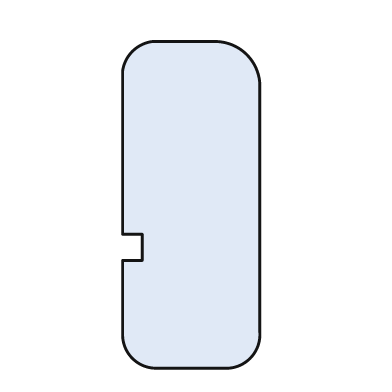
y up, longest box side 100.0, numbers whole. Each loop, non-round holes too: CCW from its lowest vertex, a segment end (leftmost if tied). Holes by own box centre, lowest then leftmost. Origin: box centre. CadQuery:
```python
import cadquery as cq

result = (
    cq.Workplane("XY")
    .moveTo(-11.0, -50.0)
    .lineTo(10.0, -50.0)
    .threePointArc((18.0, -47.0), (21.0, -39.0))
    .lineTo(21.0, 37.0)
    .threePointArc((17.0, 46.0), (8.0, 50.0))
    .lineTo(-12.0, 50.0)
    .threePointArc((-18.0, 47.0), (-21.0, 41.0))
    .lineTo(-21.0, -9.0)
    .lineTo(-15.0, -9.0)
    .lineTo(-15.0, -17.0)
    .lineTo(-21.0, -17.0)
    .lineTo(-21.0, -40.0)
    .threePointArc((-18.0, -47.0), (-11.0, -50.0))
    .close()
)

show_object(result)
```